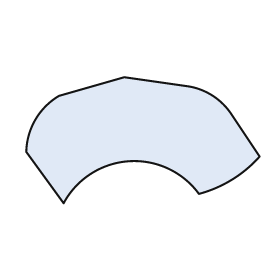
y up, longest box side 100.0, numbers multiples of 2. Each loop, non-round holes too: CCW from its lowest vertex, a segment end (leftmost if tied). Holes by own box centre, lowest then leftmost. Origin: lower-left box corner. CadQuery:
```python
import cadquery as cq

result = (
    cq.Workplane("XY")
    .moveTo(16.0, 0.0)
    .threePointArc((44.0, 18.0), (74.0, 4.0))
    .threePointArc((88.0, 10.0), (100.0, 20.0))
    .lineTo(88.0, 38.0)
    .threePointArc((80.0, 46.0), (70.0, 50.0))
    .lineTo(42.0, 54.0)
    .lineTo(14.0, 46.0)
    .threePointArc((4.0, 36.0), (0.0, 22.0))
    .close()
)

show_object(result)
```